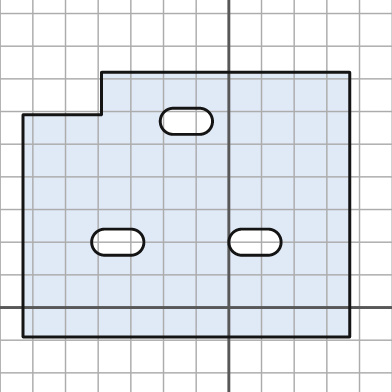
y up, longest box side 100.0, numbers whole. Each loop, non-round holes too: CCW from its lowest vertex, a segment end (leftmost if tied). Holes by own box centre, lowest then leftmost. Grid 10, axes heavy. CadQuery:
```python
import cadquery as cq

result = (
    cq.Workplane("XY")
    .moveTo(-63.0, -9.0)
    .lineTo(37.0, -9.0)
    .lineTo(37.0, 72.0)
    .lineTo(-39.0, 72.0)
    .lineTo(-39.0, 59.0)
    .lineTo(-63.0, 59.0)
    .close()
    .moveTo(-38.0, 16.0)
    .lineTo(-30.0, 16.0)
    .threePointArc((-26.0, 20.0), (-30.0, 24.0))
    .lineTo(-38.0, 24.0)
    .threePointArc((-42.0, 20.0), (-38.0, 16.0))
    .close()
    .moveTo(4.0, 16.0)
    .lineTo(12.0, 16.0)
    .threePointArc((16.0, 20.0), (12.0, 24.0))
    .lineTo(4.0, 24.0)
    .threePointArc((0.0, 20.0), (4.0, 16.0))
    .close()
    .moveTo(-17.0, 53.0)
    .lineTo(-9.0, 53.0)
    .threePointArc((-5.0, 57.0), (-9.0, 61.0))
    .lineTo(-17.0, 61.0)
    .threePointArc((-21.0, 57.0), (-17.0, 53.0))
    .close()
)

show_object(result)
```